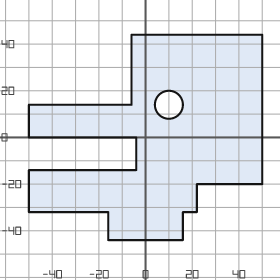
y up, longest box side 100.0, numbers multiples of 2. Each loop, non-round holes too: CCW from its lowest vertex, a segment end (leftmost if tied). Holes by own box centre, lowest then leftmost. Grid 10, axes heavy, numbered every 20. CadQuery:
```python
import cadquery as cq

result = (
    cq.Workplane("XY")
    .moveTo(-16.0, -44.0)
    .lineTo(16.0, -44.0)
    .lineTo(16.0, -32.0)
    .lineTo(22.0, -32.0)
    .lineTo(22.0, -20.0)
    .lineTo(50.0, -20.0)
    .lineTo(50.0, 44.0)
    .lineTo(-6.0, 44.0)
    .lineTo(-6.0, 14.0)
    .lineTo(-50.0, 14.0)
    .lineTo(-50.0, 0.0)
    .lineTo(-4.0, 0.0)
    .lineTo(-4.0, -14.0)
    .lineTo(-50.0, -14.0)
    .lineTo(-50.0, -32.0)
    .lineTo(-16.0, -32.0)
    .close()
    .moveTo(10.0, 14.0)
    .circle(6.0)
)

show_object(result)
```